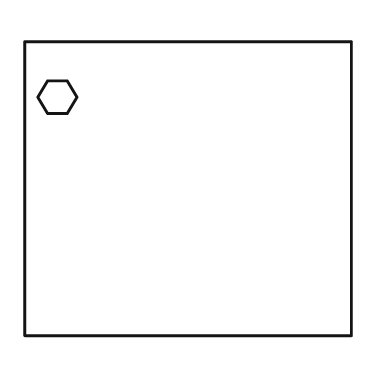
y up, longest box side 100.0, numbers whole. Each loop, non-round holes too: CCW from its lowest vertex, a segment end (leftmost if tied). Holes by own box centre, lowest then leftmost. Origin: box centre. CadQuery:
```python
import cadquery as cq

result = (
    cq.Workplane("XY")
    .moveTo(-50.0, -45.0)
    .lineTo(50.0, -45.0)
    .lineTo(50.0, 45.0)
    .lineTo(-50.0, 45.0)
    .close()
    .moveTo(-43.0, 23.0)
    .lineTo(-37.0, 23.0)
    .lineTo(-34.0, 28.0)
    .lineTo(-37.0, 33.0)
    .lineTo(-43.0, 33.0)
    .lineTo(-46.0, 28.0)
    .close()
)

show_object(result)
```